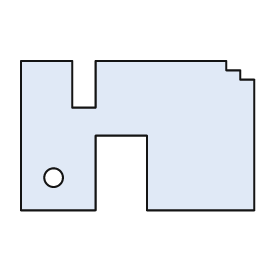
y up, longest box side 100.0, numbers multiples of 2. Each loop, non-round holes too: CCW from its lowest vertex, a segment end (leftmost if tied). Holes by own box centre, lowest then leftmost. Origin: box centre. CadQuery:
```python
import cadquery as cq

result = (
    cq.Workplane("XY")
    .moveTo(-50.0, -32.0)
    .lineTo(-18.0, -32.0)
    .lineTo(-18.0, 0.0)
    .lineTo(4.0, 0.0)
    .lineTo(4.0, -32.0)
    .lineTo(50.0, -32.0)
    .lineTo(50.0, 24.0)
    .lineTo(44.0, 24.0)
    .lineTo(44.0, 28.0)
    .lineTo(38.0, 28.0)
    .lineTo(38.0, 32.0)
    .lineTo(-18.0, 32.0)
    .lineTo(-18.0, 12.0)
    .lineTo(-28.0, 12.0)
    .lineTo(-28.0, 32.0)
    .lineTo(-50.0, 32.0)
    .close()
    .moveTo(-36.0, -18.0)
    .circle(4.0)
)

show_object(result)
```